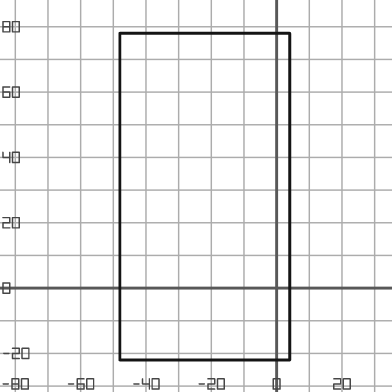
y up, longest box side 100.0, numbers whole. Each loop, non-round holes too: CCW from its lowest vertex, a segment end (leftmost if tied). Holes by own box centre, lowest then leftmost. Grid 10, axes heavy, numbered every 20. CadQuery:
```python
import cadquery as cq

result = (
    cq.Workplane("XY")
    .moveTo(-48.0, -22.0)
    .lineTo(4.0, -22.0)
    .lineTo(4.0, 78.0)
    .lineTo(-48.0, 78.0)
    .close()
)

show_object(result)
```